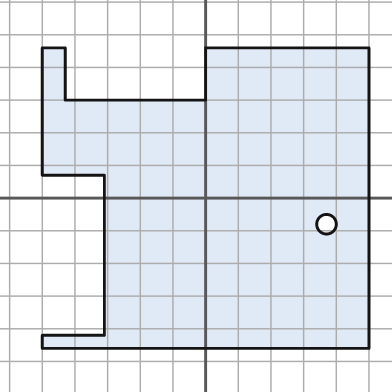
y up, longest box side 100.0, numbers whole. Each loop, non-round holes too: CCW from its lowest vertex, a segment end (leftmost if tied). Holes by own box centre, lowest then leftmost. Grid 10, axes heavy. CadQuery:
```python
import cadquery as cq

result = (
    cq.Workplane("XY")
    .moveTo(-50.0, -46.0)
    .lineTo(50.0, -46.0)
    .lineTo(50.0, 46.0)
    .lineTo(0.0, 46.0)
    .lineTo(0.0, 30.0)
    .lineTo(-43.0, 30.0)
    .lineTo(-43.0, 46.0)
    .lineTo(-50.0, 46.0)
    .lineTo(-50.0, 7.0)
    .lineTo(-31.0, 7.0)
    .lineTo(-31.0, -42.0)
    .lineTo(-50.0, -42.0)
    .close()
    .moveTo(37.0, -8.0)
    .circle(3.0)
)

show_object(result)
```